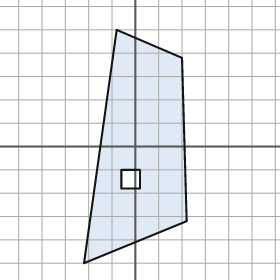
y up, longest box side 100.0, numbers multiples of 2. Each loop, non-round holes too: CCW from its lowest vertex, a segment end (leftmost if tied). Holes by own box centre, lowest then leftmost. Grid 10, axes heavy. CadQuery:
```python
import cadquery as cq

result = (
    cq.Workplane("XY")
    .moveTo(-22.0, -50.0)
    .lineTo(22.0, -32.0)
    .lineTo(20.0, 38.0)
    .lineTo(-8.0, 50.0)
    .close()
    .moveTo(-6.0, -18.0)
    .lineTo(2.0, -18.0)
    .lineTo(2.0, -10.0)
    .lineTo(-6.0, -10.0)
    .close()
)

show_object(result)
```